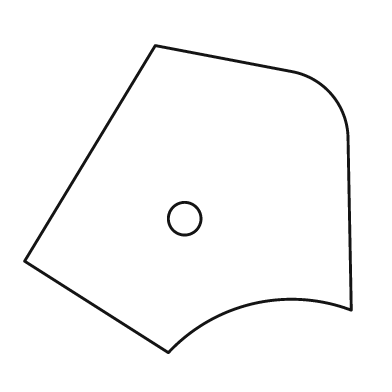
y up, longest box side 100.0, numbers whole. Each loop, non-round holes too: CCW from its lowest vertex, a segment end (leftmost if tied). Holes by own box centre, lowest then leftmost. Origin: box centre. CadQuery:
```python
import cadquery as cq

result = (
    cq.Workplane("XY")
    .moveTo(-6.0, -47.0)
    .threePointArc((20.0, -32.0), (50.0, -34.0))
    .lineTo(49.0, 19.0)
    .threePointArc((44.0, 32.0), (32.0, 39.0))
    .lineTo(-10.0, 47.0)
    .lineTo(-50.0, -19.0)
    .close()
    .moveTo(-1.0, -6.0)
    .circle(5.0)
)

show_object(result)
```